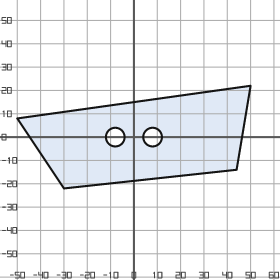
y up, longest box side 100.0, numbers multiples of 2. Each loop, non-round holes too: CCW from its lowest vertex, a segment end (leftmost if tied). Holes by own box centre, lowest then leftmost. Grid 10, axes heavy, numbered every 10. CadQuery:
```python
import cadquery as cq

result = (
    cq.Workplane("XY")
    .moveTo(-30.0, -22.0)
    .lineTo(44.0, -14.0)
    .lineTo(50.0, 22.0)
    .lineTo(-50.0, 8.0)
    .close()
    .moveTo(-8.0, 0.0)
    .circle(4.0)
    .moveTo(8.0, 0.0)
    .circle(4.0)
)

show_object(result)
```